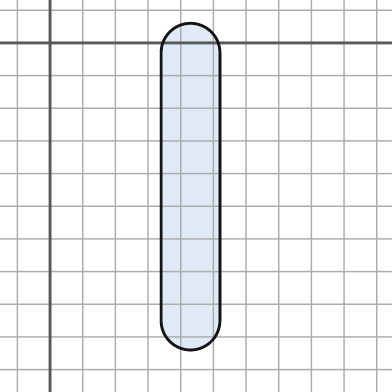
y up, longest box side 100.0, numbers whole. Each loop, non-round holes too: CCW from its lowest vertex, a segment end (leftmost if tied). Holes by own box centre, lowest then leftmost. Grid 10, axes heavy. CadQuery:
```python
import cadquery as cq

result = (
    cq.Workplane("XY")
    .moveTo(34.0, -85.0)
    .threePointArc((43.0, -94.0), (52.0, -85.0))
    .lineTo(52.0, -3.0)
    .threePointArc((43.0, 6.0), (34.0, -3.0))
    .close()
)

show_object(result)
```